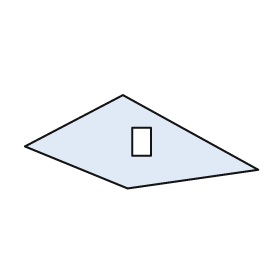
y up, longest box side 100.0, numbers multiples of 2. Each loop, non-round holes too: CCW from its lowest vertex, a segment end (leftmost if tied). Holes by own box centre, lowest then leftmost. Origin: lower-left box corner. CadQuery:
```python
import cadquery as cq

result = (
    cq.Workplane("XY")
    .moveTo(44.0, 0.0)
    .lineTo(100.0, 8.0)
    .lineTo(42.0, 40.0)
    .lineTo(0.0, 18.0)
    .close()
    .moveTo(46.0, 14.0)
    .lineTo(54.0, 14.0)
    .lineTo(54.0, 26.0)
    .lineTo(46.0, 26.0)
    .close()
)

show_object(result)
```